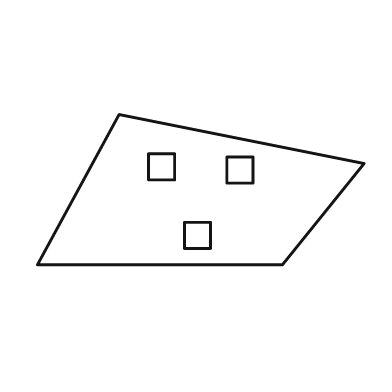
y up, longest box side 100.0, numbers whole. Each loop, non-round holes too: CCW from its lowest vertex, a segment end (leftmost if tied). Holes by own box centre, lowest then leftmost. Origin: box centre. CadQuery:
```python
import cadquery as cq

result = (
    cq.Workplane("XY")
    .moveTo(-50.0, -23.0)
    .lineTo(25.0, -23.0)
    .lineTo(50.0, 8.0)
    .lineTo(-25.0, 23.0)
    .close()
    .moveTo(-5.0, -18.0)
    .lineTo(3.0, -18.0)
    .lineTo(3.0, -10.0)
    .lineTo(-5.0, -10.0)
    .close()
    .moveTo(8.0, 2.0)
    .lineTo(16.0, 2.0)
    .lineTo(16.0, 10.0)
    .lineTo(8.0, 10.0)
    .close()
    .moveTo(-16.0, 3.0)
    .lineTo(-8.0, 3.0)
    .lineTo(-8.0, 11.0)
    .lineTo(-16.0, 11.0)
    .close()
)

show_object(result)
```